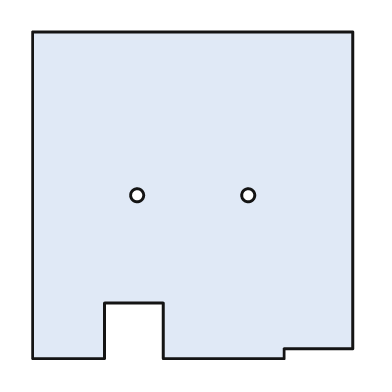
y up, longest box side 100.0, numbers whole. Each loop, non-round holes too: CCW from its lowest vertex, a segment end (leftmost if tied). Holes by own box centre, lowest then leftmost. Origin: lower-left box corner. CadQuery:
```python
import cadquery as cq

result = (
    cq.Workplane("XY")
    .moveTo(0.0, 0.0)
    .lineTo(22.0, 0.0)
    .lineTo(22.0, 17.0)
    .lineTo(40.0, 17.0)
    .lineTo(40.0, 0.0)
    .lineTo(77.0, 0.0)
    .lineTo(77.0, 3.0)
    .lineTo(98.0, 3.0)
    .lineTo(98.0, 100.0)
    .lineTo(0.0, 100.0)
    .close()
    .moveTo(32.0, 50.0)
    .circle(2.0)
    .moveTo(66.0, 50.0)
    .circle(2.0)
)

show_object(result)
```